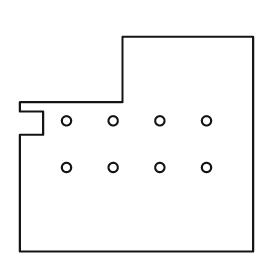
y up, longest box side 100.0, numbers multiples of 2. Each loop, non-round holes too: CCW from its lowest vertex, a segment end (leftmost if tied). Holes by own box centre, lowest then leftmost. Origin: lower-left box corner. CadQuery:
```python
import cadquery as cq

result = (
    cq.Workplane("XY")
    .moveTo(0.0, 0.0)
    .lineTo(100.0, 0.0)
    .lineTo(100.0, 92.0)
    .lineTo(44.0, 92.0)
    .lineTo(44.0, 64.0)
    .lineTo(0.0, 64.0)
    .lineTo(0.0, 60.0)
    .lineTo(10.0, 60.0)
    .lineTo(10.0, 50.0)
    .lineTo(0.0, 50.0)
    .close()
    .moveTo(20.0, 36.0)
    .circle(2.0)
    .moveTo(40.0, 36.0)
    .circle(2.0)
    .moveTo(60.0, 36.0)
    .circle(2.0)
    .moveTo(80.0, 36.0)
    .circle(2.0)
    .moveTo(20.0, 56.0)
    .circle(2.0)
    .moveTo(40.0, 56.0)
    .circle(2.0)
    .moveTo(60.0, 56.0)
    .circle(2.0)
    .moveTo(80.0, 56.0)
    .circle(2.0)
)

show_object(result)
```